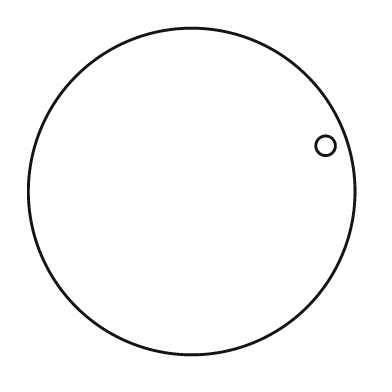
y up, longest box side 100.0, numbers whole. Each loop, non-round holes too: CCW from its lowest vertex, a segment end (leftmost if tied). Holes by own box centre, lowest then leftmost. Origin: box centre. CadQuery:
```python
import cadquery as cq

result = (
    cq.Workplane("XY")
    .moveTo(0.0, 0.0)
    .circle(50.0)
    .moveTo(41.0, 14.0)
    .circle(3.0)
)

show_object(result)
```